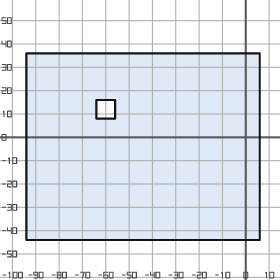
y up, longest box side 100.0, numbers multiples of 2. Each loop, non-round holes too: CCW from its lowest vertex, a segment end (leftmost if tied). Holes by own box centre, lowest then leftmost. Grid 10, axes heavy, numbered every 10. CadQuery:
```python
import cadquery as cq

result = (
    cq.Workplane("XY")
    .moveTo(-94.0, -44.0)
    .lineTo(6.0, -44.0)
    .lineTo(6.0, 36.0)
    .lineTo(-94.0, 36.0)
    .close()
    .moveTo(-64.0, 8.0)
    .lineTo(-56.0, 8.0)
    .lineTo(-56.0, 16.0)
    .lineTo(-64.0, 16.0)
    .close()
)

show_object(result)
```